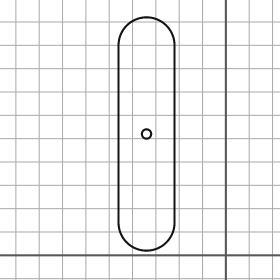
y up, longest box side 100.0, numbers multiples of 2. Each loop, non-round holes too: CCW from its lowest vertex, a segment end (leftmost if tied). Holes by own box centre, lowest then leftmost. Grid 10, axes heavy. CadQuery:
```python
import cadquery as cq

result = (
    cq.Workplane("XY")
    .moveTo(-46.0, 14.0)
    .threePointArc((-34.0, 2.0), (-22.0, 14.0))
    .lineTo(-22.0, 90.0)
    .threePointArc((-34.0, 102.0), (-46.0, 90.0))
    .close()
    .moveTo(-34.0, 52.0)
    .circle(2.0)
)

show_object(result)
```